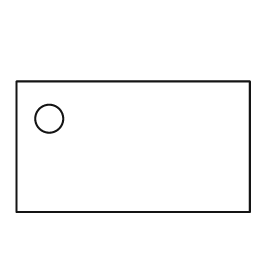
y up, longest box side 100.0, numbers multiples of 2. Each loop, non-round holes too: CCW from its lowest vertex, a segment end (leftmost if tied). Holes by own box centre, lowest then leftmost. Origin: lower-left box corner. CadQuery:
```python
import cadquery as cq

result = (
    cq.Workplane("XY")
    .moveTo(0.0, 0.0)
    .lineTo(100.0, 0.0)
    .lineTo(100.0, 56.0)
    .lineTo(0.0, 56.0)
    .close()
    .moveTo(14.0, 40.0)
    .circle(6.0)
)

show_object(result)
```